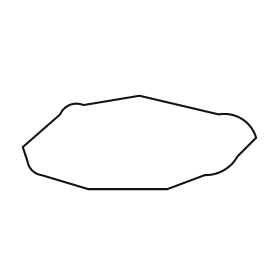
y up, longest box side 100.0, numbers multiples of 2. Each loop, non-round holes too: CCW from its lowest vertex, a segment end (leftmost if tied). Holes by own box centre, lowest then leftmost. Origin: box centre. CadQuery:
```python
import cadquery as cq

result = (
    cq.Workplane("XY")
    .moveTo(-22.0, -20.0)
    .lineTo(12.0, -20.0)
    .lineTo(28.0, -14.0)
    .threePointArc((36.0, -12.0), (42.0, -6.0))
    .lineTo(50.0, 2.0)
    .threePointArc((44.0, 10.0), (34.0, 12.0))
    .lineTo(0.0, 20.0)
    .lineTo(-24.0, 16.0)
    .threePointArc((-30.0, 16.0), (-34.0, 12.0))
    .lineTo(-50.0, -2.0)
    .lineTo(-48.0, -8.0)
    .threePointArc((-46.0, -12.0), (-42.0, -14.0))
    .close()
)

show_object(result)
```